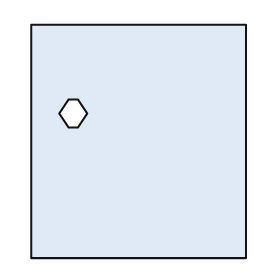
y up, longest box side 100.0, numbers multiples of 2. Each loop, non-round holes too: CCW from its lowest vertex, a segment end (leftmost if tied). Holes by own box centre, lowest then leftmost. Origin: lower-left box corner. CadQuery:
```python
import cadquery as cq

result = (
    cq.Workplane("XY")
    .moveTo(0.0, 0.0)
    .lineTo(92.0, 0.0)
    .lineTo(92.0, 100.0)
    .lineTo(0.0, 100.0)
    .close()
    .moveTo(16.0, 56.0)
    .lineTo(20.0, 56.0)
    .lineTo(24.0, 62.0)
    .lineTo(20.0, 68.0)
    .lineTo(16.0, 68.0)
    .lineTo(12.0, 62.0)
    .close()
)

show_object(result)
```